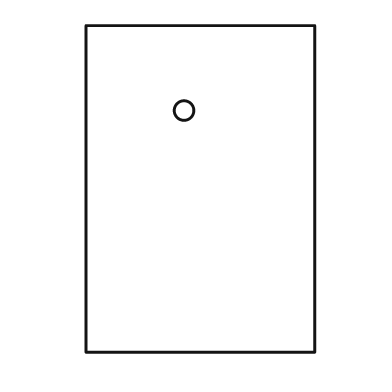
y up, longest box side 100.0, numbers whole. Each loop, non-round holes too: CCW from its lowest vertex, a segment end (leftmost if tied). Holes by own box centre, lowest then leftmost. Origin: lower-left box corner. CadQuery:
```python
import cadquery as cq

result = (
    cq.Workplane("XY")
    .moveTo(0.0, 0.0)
    .lineTo(70.0, 0.0)
    .lineTo(70.0, 100.0)
    .lineTo(0.0, 100.0)
    .close()
    .moveTo(30.0, 74.0)
    .circle(3.0)
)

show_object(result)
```